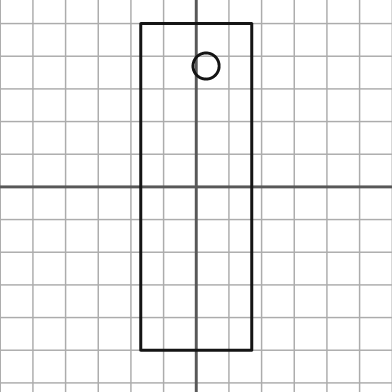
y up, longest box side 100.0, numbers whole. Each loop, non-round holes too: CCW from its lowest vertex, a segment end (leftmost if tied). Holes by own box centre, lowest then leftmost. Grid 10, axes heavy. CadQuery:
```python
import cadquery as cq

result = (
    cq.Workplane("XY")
    .moveTo(-17.0, -50.0)
    .lineTo(17.0, -50.0)
    .lineTo(17.0, 50.0)
    .lineTo(-17.0, 50.0)
    .close()
    .moveTo(3.0, 37.0)
    .circle(4.0)
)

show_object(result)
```